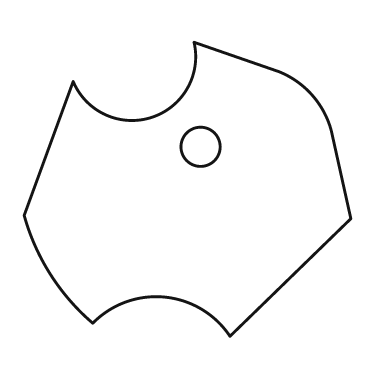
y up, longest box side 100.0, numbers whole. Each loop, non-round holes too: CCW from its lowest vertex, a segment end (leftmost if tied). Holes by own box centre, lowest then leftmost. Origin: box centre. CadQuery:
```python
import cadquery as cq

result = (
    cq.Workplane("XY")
    .moveTo(13.0, -45.0)
    .lineTo(50.0, -9.0)
    .lineTo(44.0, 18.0)
    .threePointArc((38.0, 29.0), (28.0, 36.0))
    .lineTo(2.0, 45.0)
    .threePointArc((-11.0, 22.0), (-35.0, 33.0))
    .lineTo(-50.0, -8.0)
    .threePointArc((-42.0, -26.0), (-29.0, -41.0))
    .threePointArc((-7.0, -33.0), (13.0, -45.0))
    .close()
    .moveTo(4.0, 13.0)
    .circle(6.0)
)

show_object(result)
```